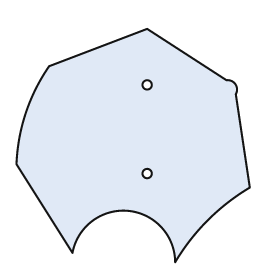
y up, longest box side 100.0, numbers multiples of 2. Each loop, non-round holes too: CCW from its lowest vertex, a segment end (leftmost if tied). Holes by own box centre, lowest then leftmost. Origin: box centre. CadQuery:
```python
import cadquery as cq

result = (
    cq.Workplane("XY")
    .moveTo(18.0, -50.0)
    .threePointArc((32.0, -32.0), (50.0, -18.0))
    .lineTo(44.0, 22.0)
    .threePointArc((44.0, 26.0), (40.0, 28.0))
    .lineTo(6.0, 50.0)
    .lineTo(-36.0, 34.0)
    .threePointArc((-46.0, 14.0), (-50.0, -8.0))
    .lineTo(-26.0, -46.0)
    .threePointArc((-2.0, -28.0), (18.0, -50.0))
    .close()
    .moveTo(6.0, -12.0)
    .circle(2.0)
    .moveTo(6.0, 26.0)
    .circle(2.0)
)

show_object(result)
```